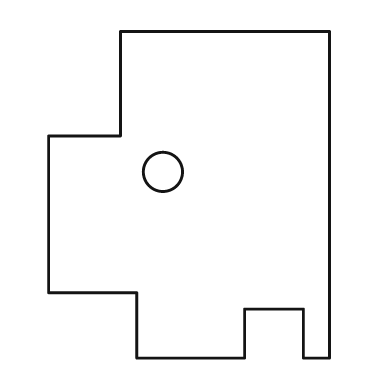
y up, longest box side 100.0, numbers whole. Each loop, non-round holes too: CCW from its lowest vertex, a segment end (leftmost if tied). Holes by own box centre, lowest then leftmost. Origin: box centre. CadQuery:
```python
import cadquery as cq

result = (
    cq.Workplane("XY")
    .moveTo(-16.0, -50.0)
    .lineTo(17.0, -50.0)
    .lineTo(17.0, -35.0)
    .lineTo(35.0, -35.0)
    .lineTo(35.0, -50.0)
    .lineTo(43.0, -50.0)
    .lineTo(43.0, 50.0)
    .lineTo(-21.0, 50.0)
    .lineTo(-21.0, 18.0)
    .lineTo(-43.0, 18.0)
    .lineTo(-43.0, -30.0)
    .lineTo(-16.0, -30.0)
    .close()
    .moveTo(-8.0, 7.0)
    .circle(6.0)
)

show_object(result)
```